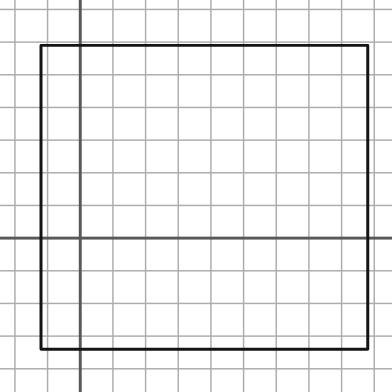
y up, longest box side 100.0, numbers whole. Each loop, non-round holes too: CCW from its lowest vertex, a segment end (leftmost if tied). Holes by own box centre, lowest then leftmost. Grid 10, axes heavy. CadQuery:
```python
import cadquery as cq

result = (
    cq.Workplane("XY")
    .moveTo(-12.0, -34.0)
    .lineTo(88.0, -34.0)
    .lineTo(88.0, 59.0)
    .lineTo(-12.0, 59.0)
    .close()
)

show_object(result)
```